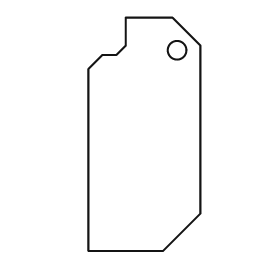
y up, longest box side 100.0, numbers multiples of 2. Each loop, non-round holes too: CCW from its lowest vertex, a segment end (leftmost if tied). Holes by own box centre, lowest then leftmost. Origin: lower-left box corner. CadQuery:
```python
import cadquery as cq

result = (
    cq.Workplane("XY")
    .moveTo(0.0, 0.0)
    .lineTo(32.0, 0.0)
    .lineTo(48.0, 16.0)
    .lineTo(48.0, 88.0)
    .lineTo(36.0, 100.0)
    .lineTo(16.0, 100.0)
    .lineTo(16.0, 88.0)
    .lineTo(12.0, 84.0)
    .lineTo(6.0, 84.0)
    .lineTo(0.0, 78.0)
    .close()
    .moveTo(38.0, 86.0)
    .circle(4.0)
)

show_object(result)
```